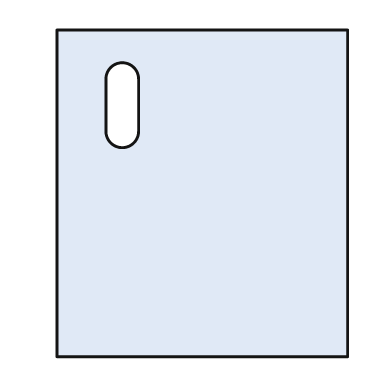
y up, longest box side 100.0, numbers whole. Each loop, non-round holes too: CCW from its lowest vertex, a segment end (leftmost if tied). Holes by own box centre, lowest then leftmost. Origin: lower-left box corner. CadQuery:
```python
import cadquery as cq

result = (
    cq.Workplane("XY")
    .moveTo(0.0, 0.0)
    .lineTo(89.0, 0.0)
    .lineTo(89.0, 100.0)
    .lineTo(0.0, 100.0)
    .close()
    .moveTo(15.0, 69.0)
    .threePointArc((20.0, 64.0), (25.0, 69.0))
    .lineTo(25.0, 85.0)
    .threePointArc((20.0, 90.0), (15.0, 85.0))
    .close()
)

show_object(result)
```